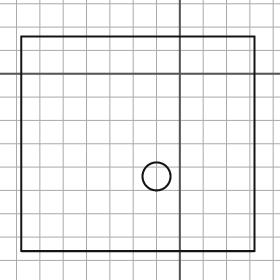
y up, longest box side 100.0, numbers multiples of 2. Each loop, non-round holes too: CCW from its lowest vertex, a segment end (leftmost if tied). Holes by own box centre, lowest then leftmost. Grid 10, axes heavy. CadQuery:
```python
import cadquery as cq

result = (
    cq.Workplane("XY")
    .moveTo(-68.0, -76.0)
    .lineTo(32.0, -76.0)
    .lineTo(32.0, 16.0)
    .lineTo(-68.0, 16.0)
    .close()
    .moveTo(-10.0, -44.0)
    .circle(6.0)
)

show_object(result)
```